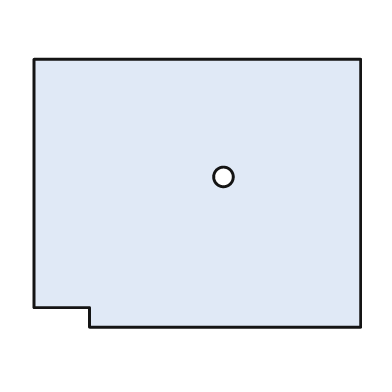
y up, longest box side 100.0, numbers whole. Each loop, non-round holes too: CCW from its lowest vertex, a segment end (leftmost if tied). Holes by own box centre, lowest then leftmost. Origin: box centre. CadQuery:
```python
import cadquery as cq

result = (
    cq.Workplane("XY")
    .moveTo(-33.0, -41.0)
    .lineTo(50.0, -41.0)
    .lineTo(50.0, 41.0)
    .lineTo(-50.0, 41.0)
    .lineTo(-50.0, -35.0)
    .lineTo(-33.0, -35.0)
    .close()
    .moveTo(8.0, 5.0)
    .circle(3.0)
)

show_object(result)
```